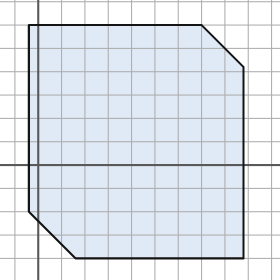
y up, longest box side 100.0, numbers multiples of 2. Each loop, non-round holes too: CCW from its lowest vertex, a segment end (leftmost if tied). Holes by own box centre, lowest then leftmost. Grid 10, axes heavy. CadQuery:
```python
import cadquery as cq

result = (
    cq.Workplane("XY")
    .moveTo(16.0, -40.0)
    .lineTo(88.0, -40.0)
    .lineTo(88.0, 42.0)
    .lineTo(70.0, 60.0)
    .lineTo(-4.0, 60.0)
    .lineTo(-4.0, -20.0)
    .close()
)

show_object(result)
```